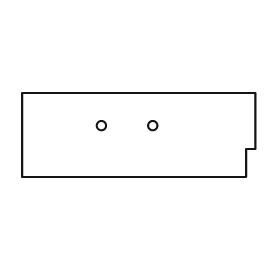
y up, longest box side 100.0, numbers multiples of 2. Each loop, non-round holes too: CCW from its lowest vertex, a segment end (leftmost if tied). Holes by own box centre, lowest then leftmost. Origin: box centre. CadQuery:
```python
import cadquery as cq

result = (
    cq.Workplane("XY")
    .moveTo(-50.0, -18.0)
    .lineTo(46.0, -18.0)
    .lineTo(46.0, -6.0)
    .lineTo(50.0, -6.0)
    .lineTo(50.0, 18.0)
    .lineTo(-50.0, 18.0)
    .close()
    .moveTo(-16.0, 4.0)
    .circle(2.0)
    .moveTo(6.0, 4.0)
    .circle(2.0)
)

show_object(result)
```